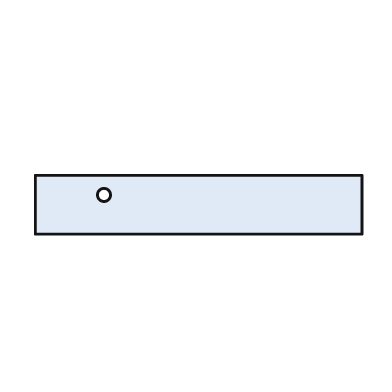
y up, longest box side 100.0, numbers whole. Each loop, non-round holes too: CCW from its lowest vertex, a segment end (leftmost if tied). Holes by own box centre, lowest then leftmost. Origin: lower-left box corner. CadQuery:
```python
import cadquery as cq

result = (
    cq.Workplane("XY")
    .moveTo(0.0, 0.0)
    .lineTo(100.0, 0.0)
    .lineTo(100.0, 18.0)
    .lineTo(0.0, 18.0)
    .close()
    .moveTo(21.0, 12.0)
    .circle(2.0)
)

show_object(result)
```